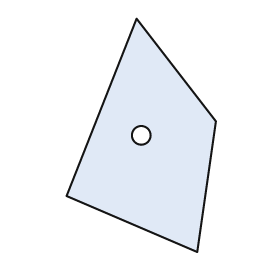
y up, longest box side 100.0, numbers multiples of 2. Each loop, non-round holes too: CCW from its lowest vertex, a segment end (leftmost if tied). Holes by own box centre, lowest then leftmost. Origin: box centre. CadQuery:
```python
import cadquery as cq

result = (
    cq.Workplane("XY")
    .moveTo(24.0, -50.0)
    .lineTo(32.0, 6.0)
    .lineTo(-2.0, 50.0)
    .lineTo(-32.0, -26.0)
    .close()
    .moveTo(0.0, 0.0)
    .circle(4.0)
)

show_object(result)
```